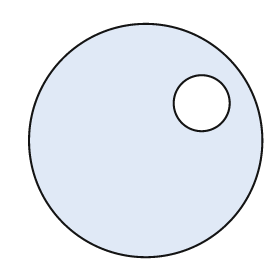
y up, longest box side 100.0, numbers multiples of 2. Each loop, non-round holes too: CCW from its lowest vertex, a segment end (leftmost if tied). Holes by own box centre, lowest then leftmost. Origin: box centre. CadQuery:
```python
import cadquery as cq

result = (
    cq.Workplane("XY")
    .moveTo(0.0, 0.0)
    .circle(50.0)
    .moveTo(24.0, 16.0)
    .circle(12.0)
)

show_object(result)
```